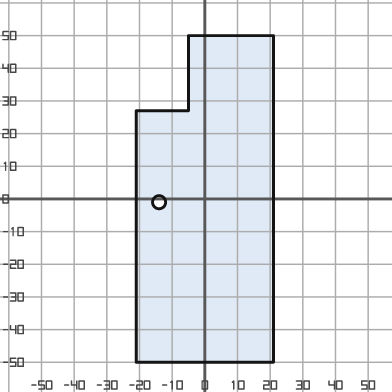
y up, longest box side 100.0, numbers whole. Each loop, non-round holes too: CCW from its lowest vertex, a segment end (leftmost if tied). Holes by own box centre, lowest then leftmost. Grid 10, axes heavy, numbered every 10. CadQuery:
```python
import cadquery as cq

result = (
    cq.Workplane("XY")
    .moveTo(-21.0, -50.0)
    .lineTo(21.0, -50.0)
    .lineTo(21.0, 50.0)
    .lineTo(-5.0, 50.0)
    .lineTo(-5.0, 27.0)
    .lineTo(-21.0, 27.0)
    .close()
    .moveTo(-14.0, -1.0)
    .circle(2.0)
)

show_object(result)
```